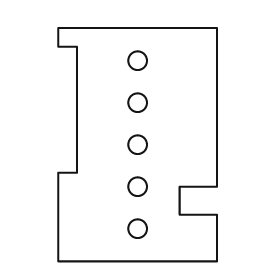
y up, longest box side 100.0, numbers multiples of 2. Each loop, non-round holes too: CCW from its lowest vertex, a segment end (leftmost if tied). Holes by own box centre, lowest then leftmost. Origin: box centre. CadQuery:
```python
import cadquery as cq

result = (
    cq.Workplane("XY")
    .moveTo(-34.0, -50.0)
    .lineTo(34.0, -50.0)
    .lineTo(34.0, -30.0)
    .lineTo(18.0, -30.0)
    .lineTo(18.0, -18.0)
    .lineTo(34.0, -18.0)
    .lineTo(34.0, 50.0)
    .lineTo(-34.0, 50.0)
    .lineTo(-34.0, 42.0)
    .lineTo(-26.0, 42.0)
    .lineTo(-26.0, -12.0)
    .lineTo(-34.0, -12.0)
    .close()
    .moveTo(0.0, -36.0)
    .circle(4.0)
    .moveTo(0.0, -18.0)
    .circle(4.0)
    .moveTo(0.0, 0.0)
    .circle(4.0)
    .moveTo(0.0, 18.0)
    .circle(4.0)
    .moveTo(0.0, 36.0)
    .circle(4.0)
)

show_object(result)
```